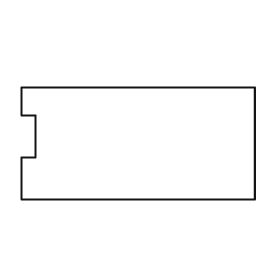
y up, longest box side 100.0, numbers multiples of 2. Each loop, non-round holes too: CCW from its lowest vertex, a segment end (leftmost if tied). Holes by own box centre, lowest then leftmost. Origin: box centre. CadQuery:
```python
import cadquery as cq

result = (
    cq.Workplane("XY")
    .moveTo(-50.0, -24.0)
    .lineTo(50.0, -24.0)
    .lineTo(50.0, 24.0)
    .lineTo(-50.0, 24.0)
    .lineTo(-50.0, 12.0)
    .lineTo(-44.0, 12.0)
    .lineTo(-44.0, -6.0)
    .lineTo(-50.0, -6.0)
    .close()
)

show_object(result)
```